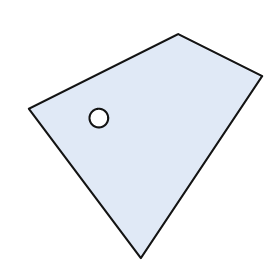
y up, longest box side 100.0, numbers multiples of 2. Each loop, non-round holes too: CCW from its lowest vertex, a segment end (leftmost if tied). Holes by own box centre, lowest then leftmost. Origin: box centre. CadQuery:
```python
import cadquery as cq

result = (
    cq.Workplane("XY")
    .moveTo(-2.0, -48.0)
    .lineTo(50.0, 30.0)
    .lineTo(14.0, 48.0)
    .lineTo(-50.0, 16.0)
    .close()
    .moveTo(-20.0, 12.0)
    .circle(4.0)
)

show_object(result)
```